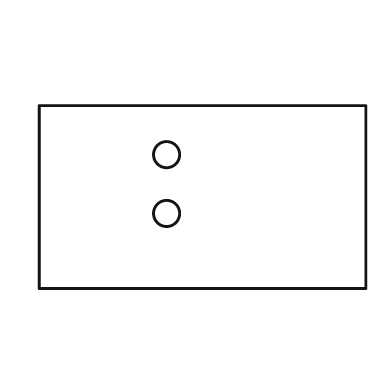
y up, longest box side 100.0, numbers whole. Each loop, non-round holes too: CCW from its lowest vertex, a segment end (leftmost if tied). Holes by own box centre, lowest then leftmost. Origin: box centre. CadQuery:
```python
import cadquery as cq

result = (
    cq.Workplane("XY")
    .moveTo(-50.0, -28.0)
    .lineTo(50.0, -28.0)
    .lineTo(50.0, 28.0)
    .lineTo(-50.0, 28.0)
    .close()
    .moveTo(-11.0, -5.0)
    .circle(4.0)
    .moveTo(-11.0, 13.0)
    .circle(4.0)
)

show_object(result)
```